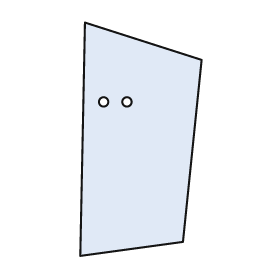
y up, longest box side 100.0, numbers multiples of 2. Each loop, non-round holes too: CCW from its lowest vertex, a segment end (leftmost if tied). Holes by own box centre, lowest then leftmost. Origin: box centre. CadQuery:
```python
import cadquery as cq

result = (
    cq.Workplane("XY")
    .moveTo(-26.0, -50.0)
    .lineTo(18.0, -44.0)
    .lineTo(26.0, 34.0)
    .lineTo(-24.0, 50.0)
    .close()
    .moveTo(-16.0, 16.0)
    .circle(2.0)
    .moveTo(-6.0, 16.0)
    .circle(2.0)
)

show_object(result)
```